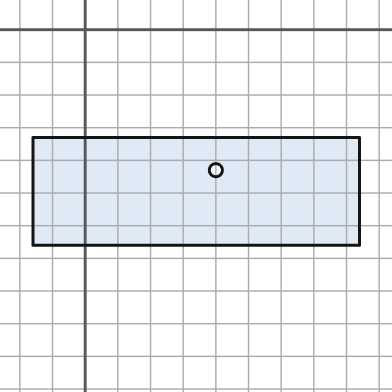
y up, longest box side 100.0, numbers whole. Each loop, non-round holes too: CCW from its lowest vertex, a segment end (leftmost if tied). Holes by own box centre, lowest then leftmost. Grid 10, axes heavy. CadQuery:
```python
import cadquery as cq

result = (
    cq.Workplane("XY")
    .moveTo(-16.0, -66.0)
    .lineTo(84.0, -66.0)
    .lineTo(84.0, -33.0)
    .lineTo(-16.0, -33.0)
    .close()
    .moveTo(40.0, -43.0)
    .circle(2.0)
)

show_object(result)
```